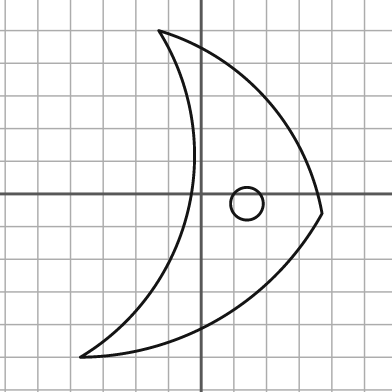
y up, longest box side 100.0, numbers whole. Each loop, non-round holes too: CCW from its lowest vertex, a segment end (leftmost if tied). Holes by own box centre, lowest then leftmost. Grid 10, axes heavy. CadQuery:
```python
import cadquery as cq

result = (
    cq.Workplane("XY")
    .moveTo(-37.0, -50.0)
    .threePointArc((6.0, -38.0), (37.0, -6.0))
    .threePointArc((20.0, 29.0), (-13.0, 50.0))
    .threePointArc((-4.0, -5.0), (-37.0, -50.0))
    .close()
    .moveTo(14.0, -3.0)
    .circle(5.0)
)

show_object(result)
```